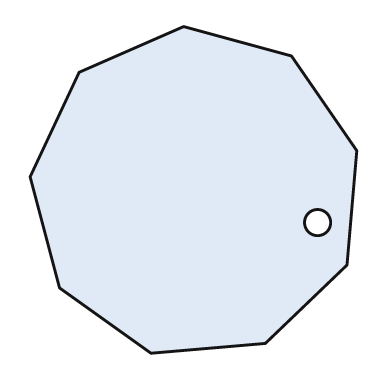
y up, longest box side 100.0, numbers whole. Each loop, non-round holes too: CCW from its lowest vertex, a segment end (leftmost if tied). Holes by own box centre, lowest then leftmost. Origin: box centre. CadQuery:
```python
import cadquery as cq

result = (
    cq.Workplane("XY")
    .moveTo(-13.0, -50.0)
    .lineTo(22.0, -47.0)
    .lineTo(47.0, -23.0)
    .lineTo(50.0, 12.0)
    .lineTo(30.0, 41.0)
    .lineTo(-3.0, 50.0)
    .lineTo(-35.0, 36.0)
    .lineTo(-50.0, 4.0)
    .lineTo(-41.0, -30.0)
    .close()
    .moveTo(38.0, -10.0)
    .circle(4.0)
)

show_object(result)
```